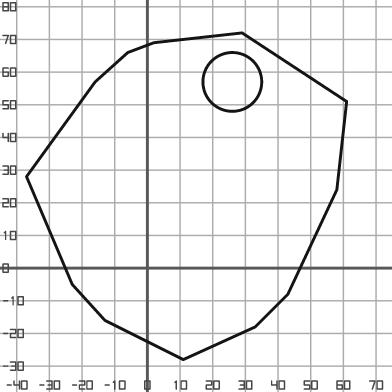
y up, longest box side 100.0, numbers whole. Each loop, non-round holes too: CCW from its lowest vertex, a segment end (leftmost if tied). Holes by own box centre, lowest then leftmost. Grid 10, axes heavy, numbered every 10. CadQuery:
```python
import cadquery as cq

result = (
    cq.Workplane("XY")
    .moveTo(11.0, -28.0)
    .lineTo(33.0, -18.0)
    .lineTo(43.0, -8.0)
    .lineTo(58.0, 24.0)
    .lineTo(61.0, 51.0)
    .lineTo(29.0, 72.0)
    .lineTo(2.0, 69.0)
    .lineTo(-6.0, 66.0)
    .lineTo(-16.0, 57.0)
    .lineTo(-37.0, 28.0)
    .lineTo(-23.0, -5.0)
    .lineTo(-13.0, -16.0)
    .close()
    .moveTo(26.0, 57.0)
    .circle(9.0)
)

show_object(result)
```